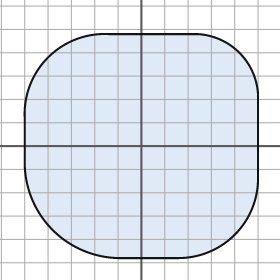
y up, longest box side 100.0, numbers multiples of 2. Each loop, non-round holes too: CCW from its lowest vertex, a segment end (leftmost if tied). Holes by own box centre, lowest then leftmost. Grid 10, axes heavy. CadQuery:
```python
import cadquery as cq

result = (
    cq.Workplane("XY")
    .moveTo(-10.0, -48.0)
    .lineTo(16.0, -48.0)
    .threePointArc((40.0, -38.0), (50.0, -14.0))
    .lineTo(50.0, 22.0)
    .threePointArc((42.0, 40.0), (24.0, 48.0))
    .lineTo(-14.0, 48.0)
    .threePointArc((-40.0, 38.0), (-50.0, 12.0))
    .lineTo(-50.0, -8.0)
    .threePointArc((-38.0, -36.0), (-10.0, -48.0))
    .close()
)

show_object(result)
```